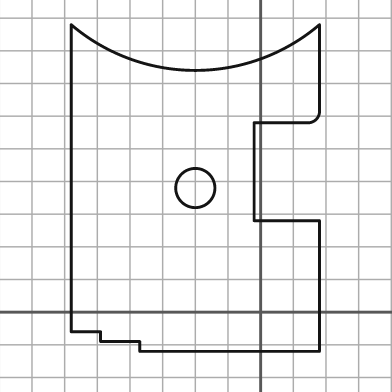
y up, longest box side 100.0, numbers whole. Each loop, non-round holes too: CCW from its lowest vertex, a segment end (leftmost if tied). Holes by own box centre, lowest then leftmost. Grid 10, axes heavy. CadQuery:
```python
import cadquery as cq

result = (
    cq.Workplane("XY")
    .moveTo(-37.0, -12.0)
    .lineTo(18.0, -12.0)
    .lineTo(18.0, 28.0)
    .lineTo(-2.0, 28.0)
    .lineTo(-2.0, 58.0)
    .lineTo(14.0, 58.0)
    .threePointArc((17.0, 59.0), (18.0, 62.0))
    .lineTo(18.0, 88.0)
    .threePointArc((-20.0, 74.0), (-58.0, 88.0))
    .lineTo(-58.0, -6.0)
    .lineTo(-49.0, -6.0)
    .lineTo(-49.0, -9.0)
    .lineTo(-37.0, -9.0)
    .close()
    .moveTo(-20.0, 38.0)
    .circle(6.0)
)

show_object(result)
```